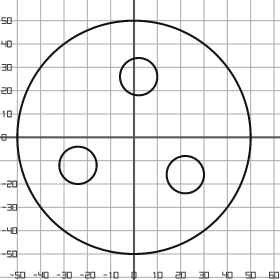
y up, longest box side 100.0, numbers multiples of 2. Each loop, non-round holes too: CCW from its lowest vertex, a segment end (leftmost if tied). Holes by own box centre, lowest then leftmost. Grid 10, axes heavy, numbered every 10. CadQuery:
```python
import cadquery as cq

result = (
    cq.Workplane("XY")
    .moveTo(0.0, 0.0)
    .circle(50.0)
    .moveTo(22.0, -16.0)
    .circle(8.0)
    .moveTo(-24.0, -12.0)
    .circle(8.0)
    .moveTo(2.0, 26.0)
    .circle(8.0)
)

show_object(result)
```